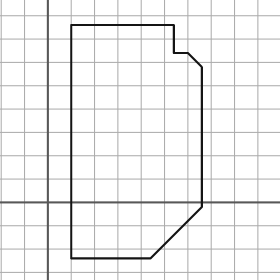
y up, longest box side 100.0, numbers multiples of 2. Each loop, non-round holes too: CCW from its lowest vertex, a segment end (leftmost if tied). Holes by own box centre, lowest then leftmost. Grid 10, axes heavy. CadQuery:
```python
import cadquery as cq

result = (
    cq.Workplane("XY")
    .moveTo(10.0, -24.0)
    .lineTo(44.0, -24.0)
    .lineTo(66.0, -2.0)
    .lineTo(66.0, 58.0)
    .lineTo(60.0, 64.0)
    .lineTo(54.0, 64.0)
    .lineTo(54.0, 76.0)
    .lineTo(10.0, 76.0)
    .close()
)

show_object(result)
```